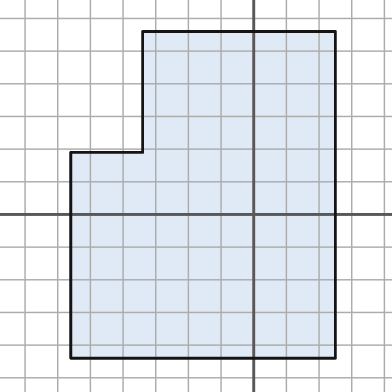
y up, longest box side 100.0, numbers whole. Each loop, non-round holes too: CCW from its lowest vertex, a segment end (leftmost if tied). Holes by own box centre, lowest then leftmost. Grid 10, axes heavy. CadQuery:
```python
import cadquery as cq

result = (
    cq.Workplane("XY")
    .moveTo(-56.0, -44.0)
    .lineTo(25.0, -44.0)
    .lineTo(25.0, 56.0)
    .lineTo(-34.0, 56.0)
    .lineTo(-34.0, 19.0)
    .lineTo(-56.0, 19.0)
    .close()
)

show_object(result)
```